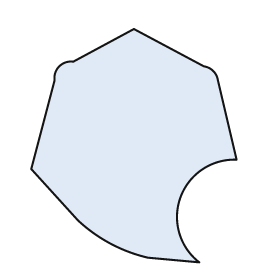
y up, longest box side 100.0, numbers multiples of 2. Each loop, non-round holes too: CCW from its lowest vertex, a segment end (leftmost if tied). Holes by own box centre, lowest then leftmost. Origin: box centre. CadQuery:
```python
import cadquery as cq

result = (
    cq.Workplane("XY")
    .moveTo(28.0, -50.0)
    .threePointArc((20.0, -22.0), (44.0, -6.0))
    .lineTo(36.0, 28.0)
    .threePointArc((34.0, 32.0), (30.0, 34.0))
    .lineTo(0.0, 50.0)
    .lineTo(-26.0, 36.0)
    .threePointArc((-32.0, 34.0), (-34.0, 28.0))
    .lineTo(-44.0, -10.0)
    .lineTo(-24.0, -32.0)
    .threePointArc((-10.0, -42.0), (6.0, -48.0))
    .close()
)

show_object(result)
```